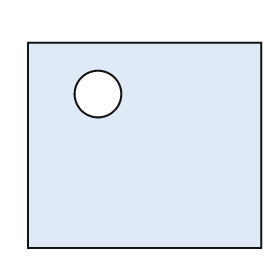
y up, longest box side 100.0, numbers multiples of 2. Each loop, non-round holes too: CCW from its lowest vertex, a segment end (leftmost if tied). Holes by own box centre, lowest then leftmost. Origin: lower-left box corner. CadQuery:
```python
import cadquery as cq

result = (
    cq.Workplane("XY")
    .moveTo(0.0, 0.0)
    .lineTo(100.0, 0.0)
    .lineTo(100.0, 88.0)
    .lineTo(0.0, 88.0)
    .close()
    .moveTo(30.0, 66.0)
    .circle(10.0)
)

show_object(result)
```